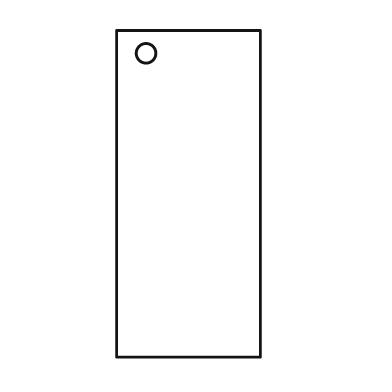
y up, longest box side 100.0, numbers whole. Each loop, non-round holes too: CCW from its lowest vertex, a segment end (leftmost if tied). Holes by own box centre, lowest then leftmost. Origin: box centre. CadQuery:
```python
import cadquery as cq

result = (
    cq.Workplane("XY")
    .moveTo(-22.0, -50.0)
    .lineTo(22.0, -50.0)
    .lineTo(22.0, 50.0)
    .lineTo(-22.0, 50.0)
    .close()
    .moveTo(-13.0, 43.0)
    .circle(3.0)
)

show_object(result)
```